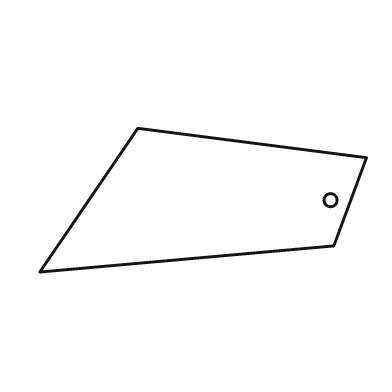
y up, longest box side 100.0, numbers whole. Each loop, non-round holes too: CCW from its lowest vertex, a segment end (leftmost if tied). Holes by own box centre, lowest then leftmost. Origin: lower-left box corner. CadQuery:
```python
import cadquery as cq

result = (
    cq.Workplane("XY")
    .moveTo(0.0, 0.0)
    .lineTo(90.0, 8.0)
    .lineTo(100.0, 35.0)
    .lineTo(30.0, 44.0)
    .close()
    .moveTo(89.0, 22.0)
    .circle(2.0)
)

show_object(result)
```